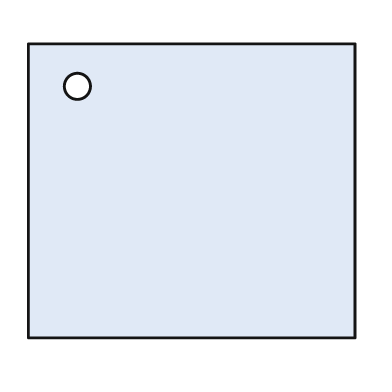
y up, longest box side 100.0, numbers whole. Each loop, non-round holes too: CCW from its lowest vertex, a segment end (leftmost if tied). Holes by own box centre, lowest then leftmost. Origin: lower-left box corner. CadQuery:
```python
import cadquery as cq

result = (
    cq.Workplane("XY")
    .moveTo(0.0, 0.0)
    .lineTo(100.0, 0.0)
    .lineTo(100.0, 90.0)
    .lineTo(0.0, 90.0)
    .close()
    .moveTo(15.0, 77.0)
    .circle(4.0)
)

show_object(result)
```